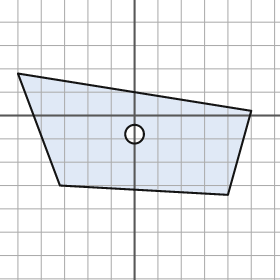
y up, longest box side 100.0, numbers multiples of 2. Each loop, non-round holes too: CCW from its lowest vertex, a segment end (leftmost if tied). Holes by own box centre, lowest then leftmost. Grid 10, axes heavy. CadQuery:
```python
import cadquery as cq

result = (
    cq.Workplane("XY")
    .moveTo(40.0, -34.0)
    .lineTo(50.0, 2.0)
    .lineTo(-50.0, 18.0)
    .lineTo(-32.0, -30.0)
    .close()
    .moveTo(0.0, -8.0)
    .circle(4.0)
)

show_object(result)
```